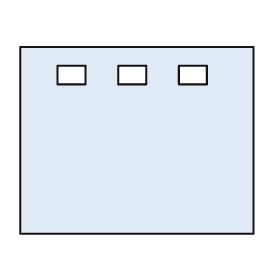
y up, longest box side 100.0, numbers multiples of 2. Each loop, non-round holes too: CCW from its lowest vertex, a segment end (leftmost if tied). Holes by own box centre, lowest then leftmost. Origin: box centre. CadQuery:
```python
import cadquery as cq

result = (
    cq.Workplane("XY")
    .moveTo(-50.0, -40.0)
    .lineTo(50.0, -40.0)
    .lineTo(50.0, 40.0)
    .lineTo(-50.0, 40.0)
    .close()
    .moveTo(-34.0, 24.0)
    .lineTo(-22.0, 24.0)
    .lineTo(-22.0, 32.0)
    .lineTo(-34.0, 32.0)
    .close()
    .moveTo(-8.0, 24.0)
    .lineTo(4.0, 24.0)
    .lineTo(4.0, 32.0)
    .lineTo(-8.0, 32.0)
    .close()
    .moveTo(18.0, 24.0)
    .lineTo(30.0, 24.0)
    .lineTo(30.0, 32.0)
    .lineTo(18.0, 32.0)
    .close()
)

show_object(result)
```